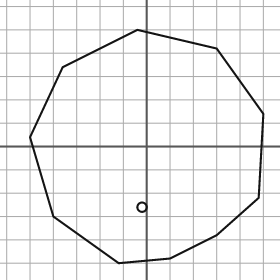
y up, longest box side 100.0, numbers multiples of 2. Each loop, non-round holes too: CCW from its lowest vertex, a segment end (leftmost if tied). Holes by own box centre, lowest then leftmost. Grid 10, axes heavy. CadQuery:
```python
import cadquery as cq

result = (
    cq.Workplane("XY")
    .moveTo(-12.0, -50.0)
    .lineTo(10.0, -48.0)
    .lineTo(30.0, -38.0)
    .lineTo(48.0, -22.0)
    .lineTo(50.0, 14.0)
    .lineTo(30.0, 42.0)
    .lineTo(-4.0, 50.0)
    .lineTo(-36.0, 34.0)
    .lineTo(-50.0, 4.0)
    .lineTo(-40.0, -30.0)
    .close()
    .moveTo(-2.0, -26.0)
    .circle(2.0)
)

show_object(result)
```